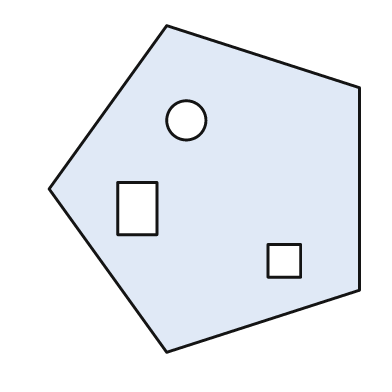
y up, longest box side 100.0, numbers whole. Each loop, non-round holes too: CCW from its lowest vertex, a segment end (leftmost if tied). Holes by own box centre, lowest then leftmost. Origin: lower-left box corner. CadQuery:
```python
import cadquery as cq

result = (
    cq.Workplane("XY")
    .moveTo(36.0, 0.0)
    .lineTo(95.0, 19.0)
    .lineTo(95.0, 81.0)
    .lineTo(36.0, 100.0)
    .lineTo(0.0, 50.0)
    .close()
    .moveTo(67.0, 23.0)
    .lineTo(77.0, 23.0)
    .lineTo(77.0, 33.0)
    .lineTo(67.0, 33.0)
    .close()
    .moveTo(21.0, 36.0)
    .lineTo(33.0, 36.0)
    .lineTo(33.0, 52.0)
    .lineTo(21.0, 52.0)
    .close()
    .moveTo(42.0, 71.0)
    .circle(6.0)
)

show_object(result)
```